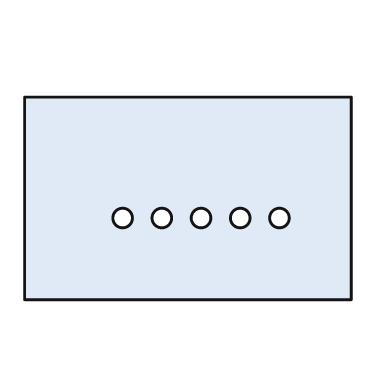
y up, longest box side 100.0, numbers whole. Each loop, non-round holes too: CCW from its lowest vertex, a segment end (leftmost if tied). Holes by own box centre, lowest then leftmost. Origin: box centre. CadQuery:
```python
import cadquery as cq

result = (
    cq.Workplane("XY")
    .moveTo(-50.0, -31.0)
    .lineTo(50.0, -31.0)
    .lineTo(50.0, 31.0)
    .lineTo(-50.0, 31.0)
    .close()
    .moveTo(-20.0, -6.0)
    .circle(3.0)
    .moveTo(-8.0, -6.0)
    .circle(3.0)
    .moveTo(4.0, -6.0)
    .circle(3.0)
    .moveTo(16.0, -6.0)
    .circle(3.0)
    .moveTo(28.0, -6.0)
    .circle(3.0)
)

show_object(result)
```